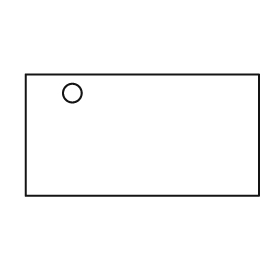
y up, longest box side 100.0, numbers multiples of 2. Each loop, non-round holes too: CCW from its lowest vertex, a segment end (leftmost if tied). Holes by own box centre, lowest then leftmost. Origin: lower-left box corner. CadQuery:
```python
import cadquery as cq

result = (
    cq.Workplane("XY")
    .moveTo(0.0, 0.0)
    .lineTo(100.0, 0.0)
    .lineTo(100.0, 52.0)
    .lineTo(0.0, 52.0)
    .close()
    .moveTo(20.0, 44.0)
    .circle(4.0)
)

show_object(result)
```